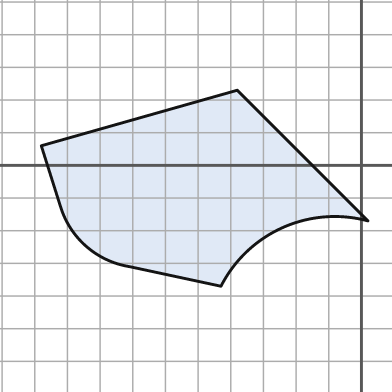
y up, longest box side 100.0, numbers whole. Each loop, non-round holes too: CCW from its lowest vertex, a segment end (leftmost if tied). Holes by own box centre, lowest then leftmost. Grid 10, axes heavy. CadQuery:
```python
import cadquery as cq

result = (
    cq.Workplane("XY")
    .moveTo(-43.0, -37.0)
    .threePointArc((-24.0, -19.0), (2.0, -17.0))
    .lineTo(-38.0, 23.0)
    .lineTo(-98.0, 6.0)
    .lineTo(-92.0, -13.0)
    .threePointArc((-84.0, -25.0), (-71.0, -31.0))
    .close()
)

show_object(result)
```